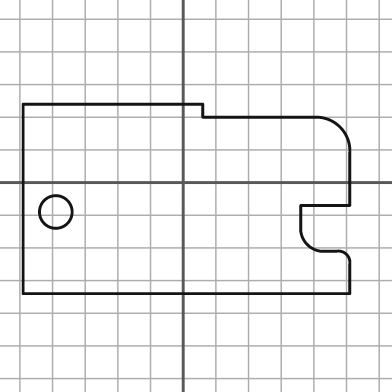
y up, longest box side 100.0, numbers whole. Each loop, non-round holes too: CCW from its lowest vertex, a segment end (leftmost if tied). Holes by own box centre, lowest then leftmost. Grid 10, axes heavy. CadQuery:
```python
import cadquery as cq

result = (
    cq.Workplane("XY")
    .moveTo(-49.0, -34.0)
    .lineTo(51.0, -34.0)
    .lineTo(51.0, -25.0)
    .threePointArc((50.0, -22.0), (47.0, -21.0))
    .lineTo(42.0, -21.0)
    .threePointArc((38.0, -19.0), (36.0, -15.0))
    .lineTo(36.0, -7.0)
    .lineTo(51.0, -7.0)
    .lineTo(51.0, 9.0)
    .threePointArc((48.0, 17.0), (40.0, 20.0))
    .lineTo(6.0, 20.0)
    .lineTo(6.0, 24.0)
    .lineTo(-49.0, 24.0)
    .close()
    .moveTo(-39.0, -9.0)
    .circle(5.0)
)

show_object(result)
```